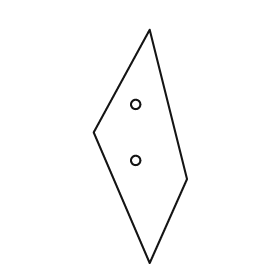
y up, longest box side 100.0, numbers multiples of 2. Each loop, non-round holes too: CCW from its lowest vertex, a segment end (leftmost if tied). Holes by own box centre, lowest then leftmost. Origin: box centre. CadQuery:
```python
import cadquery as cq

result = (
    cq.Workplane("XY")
    .moveTo(4.0, -50.0)
    .lineTo(20.0, -14.0)
    .lineTo(4.0, 50.0)
    .lineTo(-20.0, 6.0)
    .close()
    .moveTo(-2.0, -6.0)
    .circle(2.0)
    .moveTo(-2.0, 18.0)
    .circle(2.0)
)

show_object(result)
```